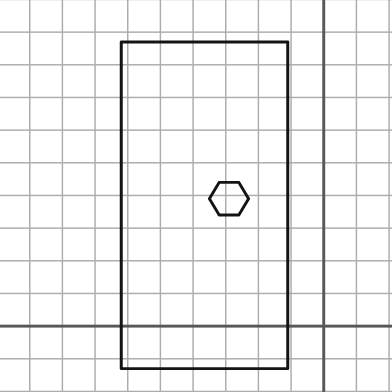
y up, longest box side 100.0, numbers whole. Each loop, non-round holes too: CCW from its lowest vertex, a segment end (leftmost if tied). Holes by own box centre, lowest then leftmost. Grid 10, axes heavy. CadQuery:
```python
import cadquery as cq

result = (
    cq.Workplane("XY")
    .moveTo(-62.0, -13.0)
    .lineTo(-11.0, -13.0)
    .lineTo(-11.0, 87.0)
    .lineTo(-62.0, 87.0)
    .close()
    .moveTo(-32.0, 34.0)
    .lineTo(-26.0, 34.0)
    .lineTo(-23.0, 39.0)
    .lineTo(-26.0, 44.0)
    .lineTo(-32.0, 44.0)
    .lineTo(-35.0, 39.0)
    .close()
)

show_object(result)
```